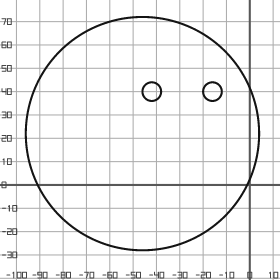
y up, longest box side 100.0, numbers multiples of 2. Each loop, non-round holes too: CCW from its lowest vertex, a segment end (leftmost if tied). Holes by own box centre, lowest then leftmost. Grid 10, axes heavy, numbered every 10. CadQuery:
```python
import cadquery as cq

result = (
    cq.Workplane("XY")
    .moveTo(-46.0, 22.0)
    .circle(50.0)
    .moveTo(-42.0, 40.0)
    .circle(4.0)
    .moveTo(-16.0, 40.0)
    .circle(4.0)
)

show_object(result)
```